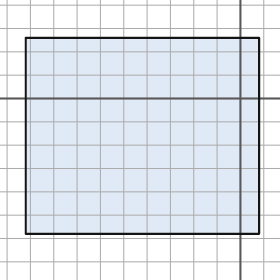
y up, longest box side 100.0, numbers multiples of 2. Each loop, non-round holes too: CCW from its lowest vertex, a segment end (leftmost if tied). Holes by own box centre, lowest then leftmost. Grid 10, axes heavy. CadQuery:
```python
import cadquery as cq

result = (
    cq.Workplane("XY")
    .moveTo(-92.0, -58.0)
    .lineTo(8.0, -58.0)
    .lineTo(8.0, 26.0)
    .lineTo(-92.0, 26.0)
    .close()
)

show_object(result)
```